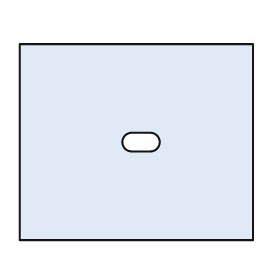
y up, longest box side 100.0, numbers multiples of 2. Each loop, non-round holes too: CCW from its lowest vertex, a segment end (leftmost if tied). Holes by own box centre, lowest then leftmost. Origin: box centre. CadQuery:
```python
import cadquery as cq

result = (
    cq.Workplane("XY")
    .moveTo(-50.0, -42.0)
    .lineTo(50.0, -42.0)
    .lineTo(50.0, 42.0)
    .lineTo(-50.0, 42.0)
    .close()
    .moveTo(-2.0, -4.0)
    .lineTo(6.0, -4.0)
    .threePointArc((10.0, 0.0), (6.0, 4.0))
    .lineTo(-2.0, 4.0)
    .threePointArc((-6.0, 0.0), (-2.0, -4.0))
    .close()
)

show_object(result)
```